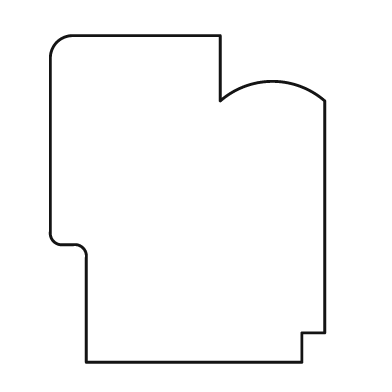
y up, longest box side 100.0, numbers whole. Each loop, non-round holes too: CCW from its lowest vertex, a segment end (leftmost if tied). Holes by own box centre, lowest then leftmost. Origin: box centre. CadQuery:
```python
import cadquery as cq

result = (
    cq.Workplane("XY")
    .moveTo(-31.0, -50.0)
    .lineTo(35.0, -50.0)
    .lineTo(35.0, -41.0)
    .lineTo(42.0, -41.0)
    .lineTo(42.0, 30.0)
    .threePointArc((26.0, 36.0), (10.0, 30.0))
    .lineTo(10.0, 50.0)
    .lineTo(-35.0, 50.0)
    .threePointArc((-40.0, 48.0), (-42.0, 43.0))
    .lineTo(-42.0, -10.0)
    .threePointArc((-41.0, -13.0), (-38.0, -14.0))
    .lineTo(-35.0, -14.0)
    .threePointArc((-32.0, -15.0), (-31.0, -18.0))
    .close()
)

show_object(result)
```